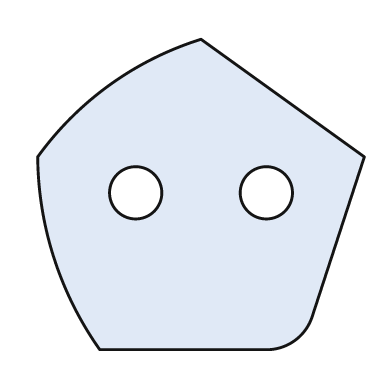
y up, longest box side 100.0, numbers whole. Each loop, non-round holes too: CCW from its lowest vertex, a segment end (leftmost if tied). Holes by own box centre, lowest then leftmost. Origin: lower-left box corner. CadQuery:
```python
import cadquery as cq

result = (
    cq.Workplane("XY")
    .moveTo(19.0, 0.0)
    .lineTo(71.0, 0.0)
    .threePointArc((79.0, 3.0), (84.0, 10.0))
    .lineTo(100.0, 59.0)
    .lineTo(50.0, 95.0)
    .threePointArc((22.0, 81.0), (0.0, 59.0))
    .threePointArc((5.0, 28.0), (19.0, 0.0))
    .close()
    .moveTo(30.0, 48.0)
    .circle(8.0)
    .moveTo(70.0, 48.0)
    .circle(8.0)
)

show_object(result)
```